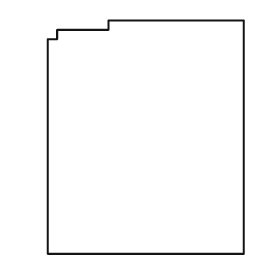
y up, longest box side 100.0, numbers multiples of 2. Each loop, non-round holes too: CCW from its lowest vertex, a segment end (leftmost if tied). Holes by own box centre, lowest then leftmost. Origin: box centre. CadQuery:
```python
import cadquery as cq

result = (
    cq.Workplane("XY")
    .moveTo(-42.0, -50.0)
    .lineTo(42.0, -50.0)
    .lineTo(42.0, 50.0)
    .lineTo(-16.0, 50.0)
    .lineTo(-16.0, 46.0)
    .lineTo(-38.0, 46.0)
    .lineTo(-38.0, 42.0)
    .lineTo(-42.0, 42.0)
    .close()
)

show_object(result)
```